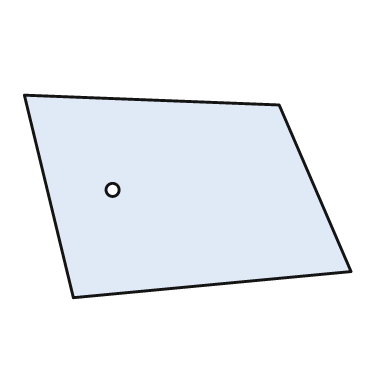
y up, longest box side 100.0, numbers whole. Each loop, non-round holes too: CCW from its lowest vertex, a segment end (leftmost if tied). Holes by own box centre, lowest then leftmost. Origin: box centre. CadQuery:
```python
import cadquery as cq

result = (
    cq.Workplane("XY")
    .moveTo(-35.0, -31.0)
    .lineTo(50.0, -23.0)
    .lineTo(28.0, 28.0)
    .lineTo(-50.0, 31.0)
    .close()
    .moveTo(-23.0, 2.0)
    .circle(2.0)
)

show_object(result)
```